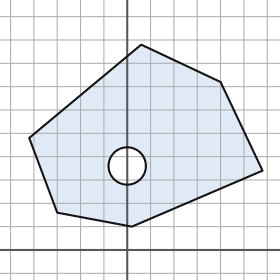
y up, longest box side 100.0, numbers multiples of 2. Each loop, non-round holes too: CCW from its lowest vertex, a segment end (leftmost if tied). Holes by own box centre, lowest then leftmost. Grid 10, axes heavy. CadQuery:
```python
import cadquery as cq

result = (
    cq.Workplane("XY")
    .moveTo(2.0, 10.0)
    .lineTo(58.0, 34.0)
    .lineTo(40.0, 72.0)
    .lineTo(6.0, 88.0)
    .lineTo(-42.0, 48.0)
    .lineTo(-30.0, 16.0)
    .close()
    .moveTo(0.0, 36.0)
    .circle(8.0)
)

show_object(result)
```